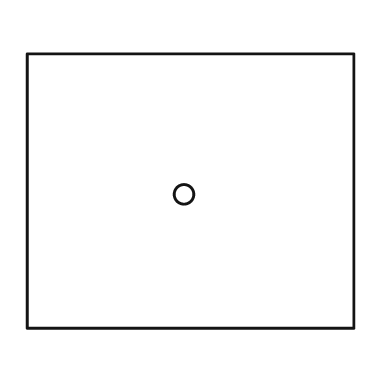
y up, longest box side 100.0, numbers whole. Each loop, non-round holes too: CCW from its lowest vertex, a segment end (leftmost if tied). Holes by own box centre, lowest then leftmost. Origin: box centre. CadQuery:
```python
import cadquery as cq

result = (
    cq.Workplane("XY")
    .moveTo(-50.0, -42.0)
    .lineTo(50.0, -42.0)
    .lineTo(50.0, 42.0)
    .lineTo(-50.0, 42.0)
    .close()
    .moveTo(-2.0, -1.0)
    .circle(3.0)
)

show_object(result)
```